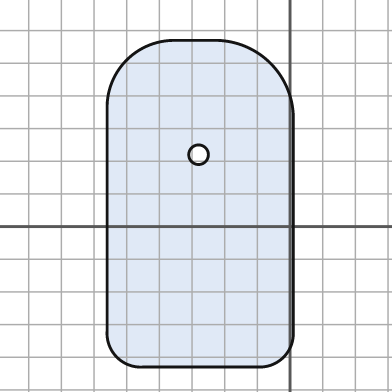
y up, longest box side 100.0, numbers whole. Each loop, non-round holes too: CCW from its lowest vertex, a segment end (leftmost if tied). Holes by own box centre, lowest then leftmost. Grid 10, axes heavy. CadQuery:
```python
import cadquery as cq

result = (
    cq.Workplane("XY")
    .moveTo(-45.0, -43.0)
    .lineTo(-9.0, -43.0)
    .threePointArc((-2.0, -40.0), (1.0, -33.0))
    .lineTo(1.0, 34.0)
    .threePointArc((-6.0, 50.0), (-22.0, 57.0))
    .lineTo(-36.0, 57.0)
    .threePointArc((-50.0, 51.0), (-56.0, 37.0))
    .lineTo(-56.0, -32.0)
    .threePointArc((-53.0, -40.0), (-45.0, -43.0))
    .close()
    .moveTo(-28.0, 22.0)
    .circle(3.0)
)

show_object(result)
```